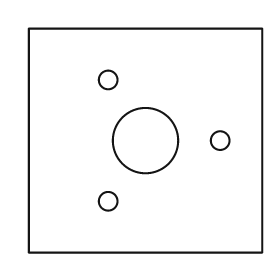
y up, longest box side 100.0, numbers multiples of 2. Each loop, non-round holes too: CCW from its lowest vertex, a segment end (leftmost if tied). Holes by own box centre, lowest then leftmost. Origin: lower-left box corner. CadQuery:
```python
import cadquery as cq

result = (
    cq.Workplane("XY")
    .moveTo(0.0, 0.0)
    .lineTo(100.0, 0.0)
    .lineTo(100.0, 96.0)
    .lineTo(0.0, 96.0)
    .close()
    .moveTo(34.0, 22.0)
    .circle(4.0)
    .moveTo(50.0, 48.0)
    .circle(14.0)
    .moveTo(82.0, 48.0)
    .circle(4.0)
    .moveTo(34.0, 74.0)
    .circle(4.0)
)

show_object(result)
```